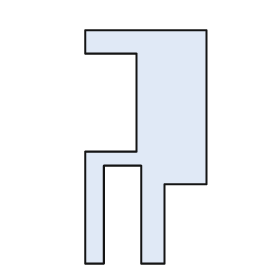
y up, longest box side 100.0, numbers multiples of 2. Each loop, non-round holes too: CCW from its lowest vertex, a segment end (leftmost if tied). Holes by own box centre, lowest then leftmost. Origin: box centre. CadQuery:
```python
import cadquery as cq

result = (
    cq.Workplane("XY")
    .moveTo(-26.0, -50.0)
    .lineTo(-18.0, -50.0)
    .lineTo(-18.0, -8.0)
    .lineTo(-2.0, -8.0)
    .lineTo(-2.0, -50.0)
    .lineTo(8.0, -50.0)
    .lineTo(8.0, -16.0)
    .lineTo(26.0, -16.0)
    .lineTo(26.0, 50.0)
    .lineTo(-26.0, 50.0)
    .lineTo(-26.0, 40.0)
    .lineTo(-4.0, 40.0)
    .lineTo(-4.0, -2.0)
    .lineTo(-26.0, -2.0)
    .close()
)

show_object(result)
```